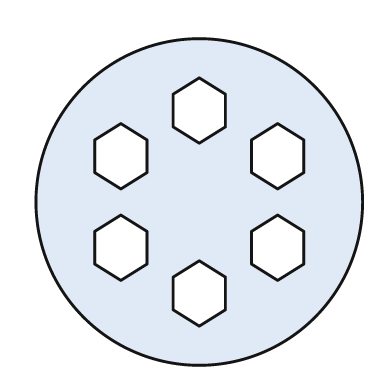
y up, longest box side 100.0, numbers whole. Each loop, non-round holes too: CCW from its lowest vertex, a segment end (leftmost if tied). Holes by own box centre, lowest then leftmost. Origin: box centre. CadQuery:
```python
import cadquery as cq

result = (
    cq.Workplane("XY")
    .moveTo(0.0, 0.0)
    .circle(50.0)
    .moveTo(0.0, -38.0)
    .lineTo(8.0, -33.0)
    .lineTo(8.0, -23.0)
    .lineTo(0.0, -18.0)
    .lineTo(-8.0, -23.0)
    .lineTo(-8.0, -33.0)
    .close()
    .moveTo(-24.0, -24.0)
    .lineTo(-16.0, -19.0)
    .lineTo(-16.0, -9.0)
    .lineTo(-24.0, -4.0)
    .lineTo(-32.0, -9.0)
    .lineTo(-32.0, -19.0)
    .close()
    .moveTo(24.0, -24.0)
    .lineTo(32.0, -19.0)
    .lineTo(32.0, -9.0)
    .lineTo(24.0, -4.0)
    .lineTo(16.0, -9.0)
    .lineTo(16.0, -19.0)
    .close()
    .moveTo(-24.0, 4.0)
    .lineTo(-16.0, 9.0)
    .lineTo(-16.0, 19.0)
    .lineTo(-24.0, 24.0)
    .lineTo(-32.0, 19.0)
    .lineTo(-32.0, 9.0)
    .close()
    .moveTo(24.0, 4.0)
    .lineTo(32.0, 9.0)
    .lineTo(32.0, 19.0)
    .lineTo(24.0, 24.0)
    .lineTo(16.0, 19.0)
    .lineTo(16.0, 9.0)
    .close()
    .moveTo(0.0, 18.0)
    .lineTo(8.0, 23.0)
    .lineTo(8.0, 33.0)
    .lineTo(0.0, 38.0)
    .lineTo(-8.0, 33.0)
    .lineTo(-8.0, 23.0)
    .close()
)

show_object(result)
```